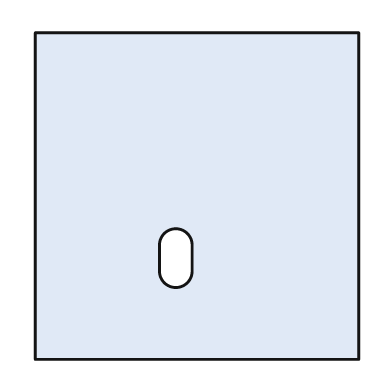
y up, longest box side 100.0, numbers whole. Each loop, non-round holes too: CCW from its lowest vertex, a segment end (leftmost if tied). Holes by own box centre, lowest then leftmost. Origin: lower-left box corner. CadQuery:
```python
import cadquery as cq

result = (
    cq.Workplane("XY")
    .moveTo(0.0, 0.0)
    .lineTo(99.0, 0.0)
    .lineTo(99.0, 100.0)
    .lineTo(0.0, 100.0)
    .close()
    .moveTo(38.0, 27.0)
    .threePointArc((43.0, 22.0), (48.0, 27.0))
    .lineTo(48.0, 35.0)
    .threePointArc((43.0, 40.0), (38.0, 35.0))
    .close()
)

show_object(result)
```